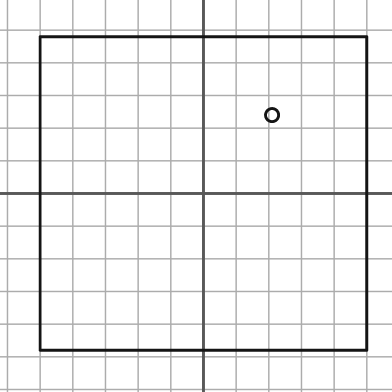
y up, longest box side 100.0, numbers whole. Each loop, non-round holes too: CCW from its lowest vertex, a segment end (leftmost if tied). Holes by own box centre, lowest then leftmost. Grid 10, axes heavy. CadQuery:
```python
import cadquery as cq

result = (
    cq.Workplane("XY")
    .moveTo(-50.0, -48.0)
    .lineTo(50.0, -48.0)
    .lineTo(50.0, 48.0)
    .lineTo(-50.0, 48.0)
    .close()
    .moveTo(21.0, 24.0)
    .circle(2.0)
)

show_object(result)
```